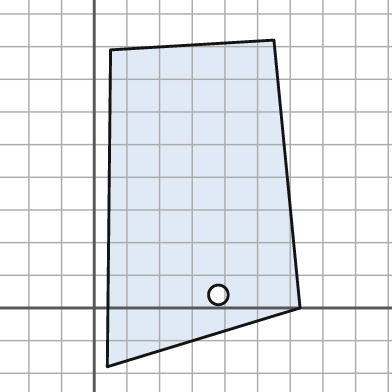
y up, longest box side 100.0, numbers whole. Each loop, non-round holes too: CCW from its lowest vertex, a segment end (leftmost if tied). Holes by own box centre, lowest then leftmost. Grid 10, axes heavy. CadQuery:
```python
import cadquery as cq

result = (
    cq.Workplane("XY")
    .moveTo(4.0, -18.0)
    .lineTo(63.0, 0.0)
    .lineTo(55.0, 82.0)
    .lineTo(5.0, 79.0)
    .close()
    .moveTo(38.0, 4.0)
    .circle(3.0)
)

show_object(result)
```